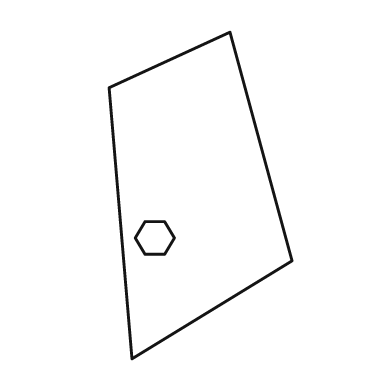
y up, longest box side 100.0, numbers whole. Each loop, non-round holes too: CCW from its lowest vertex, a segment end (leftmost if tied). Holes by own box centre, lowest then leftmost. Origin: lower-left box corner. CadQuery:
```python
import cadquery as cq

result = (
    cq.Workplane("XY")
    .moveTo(7.0, 0.0)
    .lineTo(56.0, 30.0)
    .lineTo(37.0, 100.0)
    .lineTo(0.0, 83.0)
    .close()
    .moveTo(11.0, 32.0)
    .lineTo(17.0, 32.0)
    .lineTo(20.0, 37.0)
    .lineTo(17.0, 42.0)
    .lineTo(11.0, 42.0)
    .lineTo(8.0, 37.0)
    .close()
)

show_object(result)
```